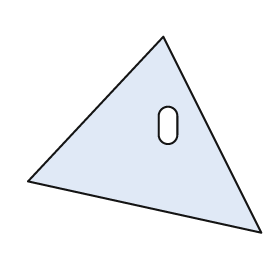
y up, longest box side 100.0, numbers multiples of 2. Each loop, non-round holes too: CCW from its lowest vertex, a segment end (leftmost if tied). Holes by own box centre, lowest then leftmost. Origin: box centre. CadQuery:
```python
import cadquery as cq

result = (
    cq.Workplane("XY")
    .moveTo(50.0, -42.0)
    .lineTo(8.0, 42.0)
    .lineTo(-50.0, -20.0)
    .close()
    .moveTo(6.0, 0.0)
    .threePointArc((10.0, -4.0), (14.0, 0.0))
    .lineTo(14.0, 8.0)
    .threePointArc((10.0, 12.0), (6.0, 8.0))
    .close()
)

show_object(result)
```